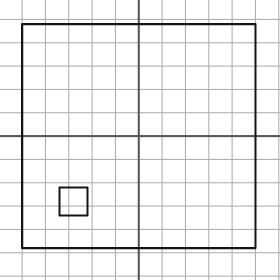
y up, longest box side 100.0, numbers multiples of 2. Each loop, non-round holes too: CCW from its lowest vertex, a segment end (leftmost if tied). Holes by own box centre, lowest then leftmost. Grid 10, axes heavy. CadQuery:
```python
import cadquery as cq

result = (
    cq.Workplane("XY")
    .moveTo(-50.0, -48.0)
    .lineTo(50.0, -48.0)
    .lineTo(50.0, 48.0)
    .lineTo(-50.0, 48.0)
    .close()
    .moveTo(-34.0, -34.0)
    .lineTo(-22.0, -34.0)
    .lineTo(-22.0, -22.0)
    .lineTo(-34.0, -22.0)
    .close()
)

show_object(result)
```